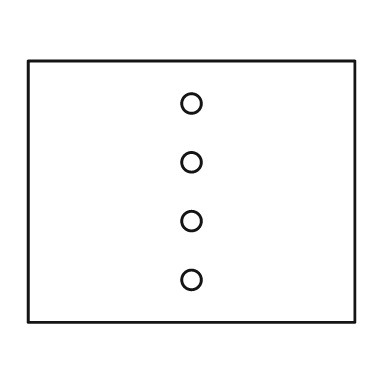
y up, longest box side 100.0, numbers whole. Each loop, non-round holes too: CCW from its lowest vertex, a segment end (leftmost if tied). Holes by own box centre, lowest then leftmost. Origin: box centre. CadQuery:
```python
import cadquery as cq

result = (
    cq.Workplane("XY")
    .moveTo(-50.0, -40.0)
    .lineTo(50.0, -40.0)
    .lineTo(50.0, 40.0)
    .lineTo(-50.0, 40.0)
    .close()
    .moveTo(0.0, -27.0)
    .circle(3.0)
    .moveTo(0.0, -9.0)
    .circle(3.0)
    .moveTo(0.0, 9.0)
    .circle(3.0)
    .moveTo(0.0, 27.0)
    .circle(3.0)
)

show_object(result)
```